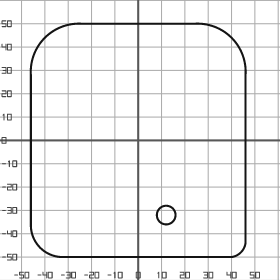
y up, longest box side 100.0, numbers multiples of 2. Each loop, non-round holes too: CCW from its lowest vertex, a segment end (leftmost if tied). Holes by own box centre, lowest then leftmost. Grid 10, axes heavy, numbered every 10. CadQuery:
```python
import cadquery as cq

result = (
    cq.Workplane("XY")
    .moveTo(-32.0, -50.0)
    .lineTo(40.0, -50.0)
    .threePointArc((44.0, -48.0), (46.0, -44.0))
    .lineTo(46.0, 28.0)
    .threePointArc((40.0, 44.0), (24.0, 50.0))
    .lineTo(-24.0, 50.0)
    .threePointArc((-40.0, 44.0), (-46.0, 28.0))
    .lineTo(-46.0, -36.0)
    .threePointArc((-42.0, -46.0), (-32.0, -50.0))
    .close()
    .moveTo(12.0, -32.0)
    .circle(4.0)
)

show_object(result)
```